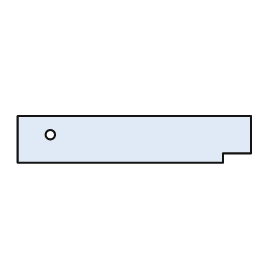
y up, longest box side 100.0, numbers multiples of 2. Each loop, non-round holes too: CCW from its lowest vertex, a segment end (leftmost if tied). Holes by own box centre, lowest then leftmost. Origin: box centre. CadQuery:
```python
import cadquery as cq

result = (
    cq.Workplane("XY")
    .moveTo(-50.0, -10.0)
    .lineTo(38.0, -10.0)
    .lineTo(38.0, -6.0)
    .lineTo(50.0, -6.0)
    .lineTo(50.0, 10.0)
    .lineTo(-50.0, 10.0)
    .close()
    .moveTo(-36.0, 2.0)
    .circle(2.0)
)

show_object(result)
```